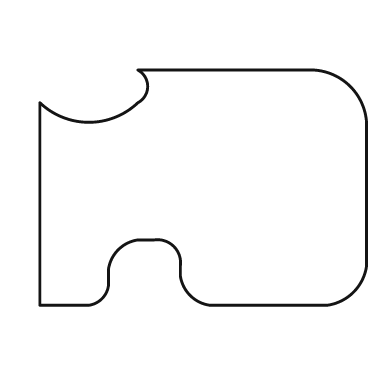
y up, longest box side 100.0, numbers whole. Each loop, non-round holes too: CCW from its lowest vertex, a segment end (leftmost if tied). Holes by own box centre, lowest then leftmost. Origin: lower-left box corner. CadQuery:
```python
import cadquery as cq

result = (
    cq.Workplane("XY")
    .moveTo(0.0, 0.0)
    .lineTo(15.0, 0.0)
    .threePointArc((19.0, 2.0), (21.0, 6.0))
    .lineTo(21.0, 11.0)
    .threePointArc((24.0, 17.0), (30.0, 20.0))
    .lineTo(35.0, 20.0)
    .threePointArc((41.0, 18.0), (43.0, 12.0))
    .lineTo(43.0, 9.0)
    .threePointArc((46.0, 3.0), (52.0, 0.0))
    .lineTo(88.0, 0.0)
    .threePointArc((96.0, 4.0), (100.0, 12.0))
    .lineTo(100.0, 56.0)
    .threePointArc((95.0, 67.0), (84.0, 72.0))
    .lineTo(30.0, 72.0)
    .threePointArc((33.0, 67.0), (30.0, 62.0))
    .threePointArc((15.0, 56.0), (0.0, 62.0))
    .close()
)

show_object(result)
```